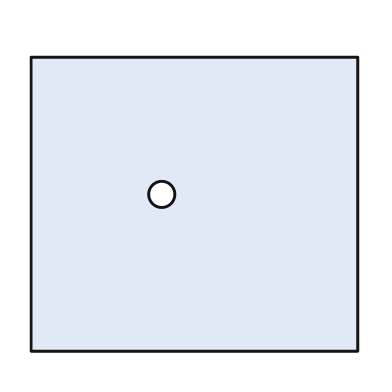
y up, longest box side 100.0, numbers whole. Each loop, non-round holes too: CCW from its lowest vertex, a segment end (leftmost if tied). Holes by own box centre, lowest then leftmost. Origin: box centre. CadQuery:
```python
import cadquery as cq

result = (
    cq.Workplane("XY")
    .moveTo(-50.0, -45.0)
    .lineTo(50.0, -45.0)
    .lineTo(50.0, 45.0)
    .lineTo(-50.0, 45.0)
    .close()
    .moveTo(-10.0, 3.0)
    .circle(4.0)
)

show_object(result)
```